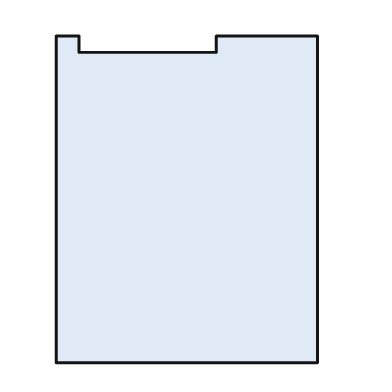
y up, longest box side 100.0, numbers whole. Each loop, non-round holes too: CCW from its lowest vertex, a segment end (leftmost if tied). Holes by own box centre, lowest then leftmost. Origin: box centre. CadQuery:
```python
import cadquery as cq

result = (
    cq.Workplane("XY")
    .moveTo(-40.0, -50.0)
    .lineTo(40.0, -50.0)
    .lineTo(40.0, 50.0)
    .lineTo(9.0, 50.0)
    .lineTo(9.0, 45.0)
    .lineTo(-33.0, 45.0)
    .lineTo(-33.0, 50.0)
    .lineTo(-40.0, 50.0)
    .close()
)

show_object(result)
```